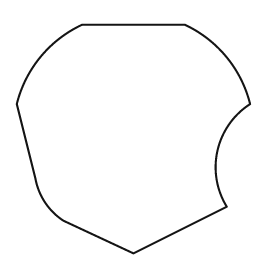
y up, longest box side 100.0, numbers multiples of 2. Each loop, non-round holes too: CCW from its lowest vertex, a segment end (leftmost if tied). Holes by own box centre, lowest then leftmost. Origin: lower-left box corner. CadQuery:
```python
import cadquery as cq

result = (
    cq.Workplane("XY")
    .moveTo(50.0, 0.0)
    .lineTo(90.0, 20.0)
    .threePointArc((86.0, 44.0), (100.0, 64.0))
    .threePointArc((90.0, 84.0), (72.0, 98.0))
    .lineTo(28.0, 98.0)
    .threePointArc((10.0, 84.0), (0.0, 64.0))
    .lineTo(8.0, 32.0)
    .threePointArc((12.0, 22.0), (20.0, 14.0))
    .close()
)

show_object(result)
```